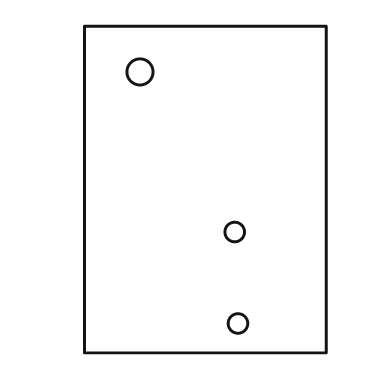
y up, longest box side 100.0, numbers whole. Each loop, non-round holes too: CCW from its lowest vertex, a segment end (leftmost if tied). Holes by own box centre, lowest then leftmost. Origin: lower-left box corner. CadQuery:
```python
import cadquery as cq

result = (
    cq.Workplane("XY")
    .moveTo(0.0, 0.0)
    .lineTo(74.0, 0.0)
    .lineTo(74.0, 100.0)
    .lineTo(0.0, 100.0)
    .close()
    .moveTo(47.0, 9.0)
    .circle(3.0)
    .moveTo(46.0, 37.0)
    .circle(3.0)
    .moveTo(17.0, 86.0)
    .circle(4.0)
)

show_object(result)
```